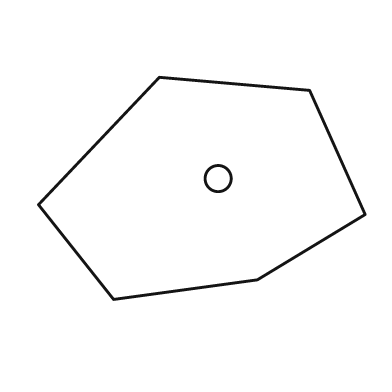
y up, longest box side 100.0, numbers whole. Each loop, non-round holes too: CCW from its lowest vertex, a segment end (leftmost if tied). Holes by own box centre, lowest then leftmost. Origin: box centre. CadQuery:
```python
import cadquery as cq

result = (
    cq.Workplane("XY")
    .moveTo(-27.0, -34.0)
    .lineTo(17.0, -28.0)
    .lineTo(50.0, -8.0)
    .lineTo(33.0, 30.0)
    .lineTo(-13.0, 34.0)
    .lineTo(-50.0, -5.0)
    .close()
    .moveTo(5.0, 3.0)
    .circle(4.0)
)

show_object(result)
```